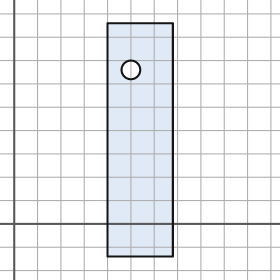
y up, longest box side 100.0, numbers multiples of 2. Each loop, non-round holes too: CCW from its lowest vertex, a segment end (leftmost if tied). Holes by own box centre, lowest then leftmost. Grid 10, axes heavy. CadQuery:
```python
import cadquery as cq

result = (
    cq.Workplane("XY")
    .moveTo(40.0, -14.0)
    .lineTo(68.0, -14.0)
    .lineTo(68.0, 86.0)
    .lineTo(40.0, 86.0)
    .close()
    .moveTo(50.0, 66.0)
    .circle(4.0)
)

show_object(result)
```